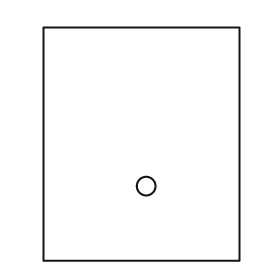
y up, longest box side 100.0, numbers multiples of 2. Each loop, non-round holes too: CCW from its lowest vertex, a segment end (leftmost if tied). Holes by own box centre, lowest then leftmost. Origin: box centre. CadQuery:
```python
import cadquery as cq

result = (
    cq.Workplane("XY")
    .moveTo(-42.0, -50.0)
    .lineTo(42.0, -50.0)
    .lineTo(42.0, 50.0)
    .lineTo(-42.0, 50.0)
    .close()
    .moveTo(2.0, -18.0)
    .circle(4.0)
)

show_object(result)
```